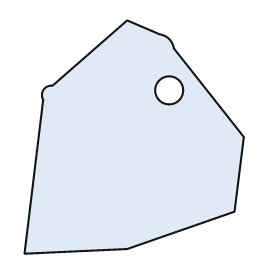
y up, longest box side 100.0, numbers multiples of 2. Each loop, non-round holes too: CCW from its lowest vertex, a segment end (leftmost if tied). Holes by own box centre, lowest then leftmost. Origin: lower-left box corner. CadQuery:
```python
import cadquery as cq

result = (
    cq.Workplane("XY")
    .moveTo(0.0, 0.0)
    .lineTo(44.0, 2.0)
    .lineTo(90.0, 18.0)
    .lineTo(94.0, 50.0)
    .lineTo(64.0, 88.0)
    .threePointArc((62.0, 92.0), (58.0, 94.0))
    .lineTo(44.0, 100.0)
    .lineTo(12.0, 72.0)
    .threePointArc((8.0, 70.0), (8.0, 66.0))
    .close()
    .moveTo(62.0, 70.0)
    .circle(6.0)
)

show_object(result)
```